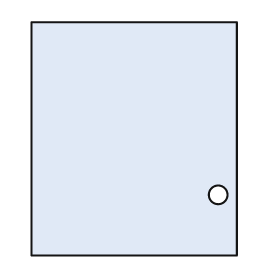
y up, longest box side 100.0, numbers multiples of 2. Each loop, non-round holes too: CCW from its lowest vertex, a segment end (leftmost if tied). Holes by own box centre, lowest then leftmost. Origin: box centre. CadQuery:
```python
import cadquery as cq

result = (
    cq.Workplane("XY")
    .moveTo(-44.0, -50.0)
    .lineTo(44.0, -50.0)
    .lineTo(44.0, 50.0)
    .lineTo(-44.0, 50.0)
    .close()
    .moveTo(36.0, -24.0)
    .circle(4.0)
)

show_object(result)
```